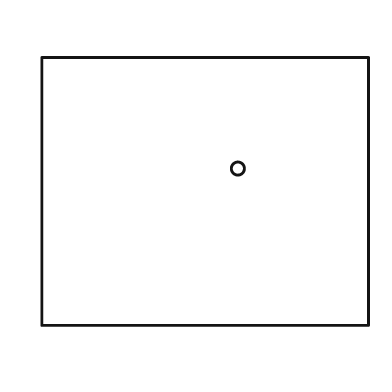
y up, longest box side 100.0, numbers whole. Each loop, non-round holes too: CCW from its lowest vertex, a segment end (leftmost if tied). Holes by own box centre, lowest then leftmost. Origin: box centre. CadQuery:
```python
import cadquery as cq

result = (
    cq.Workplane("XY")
    .moveTo(-50.0, -41.0)
    .lineTo(50.0, -41.0)
    .lineTo(50.0, 41.0)
    .lineTo(-50.0, 41.0)
    .close()
    .moveTo(10.0, 7.0)
    .circle(2.0)
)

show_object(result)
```